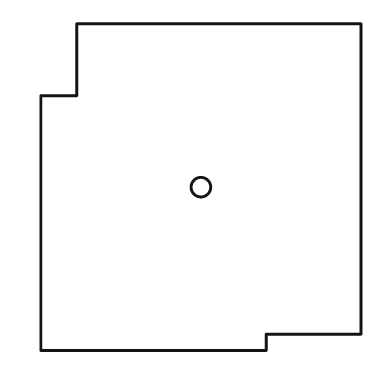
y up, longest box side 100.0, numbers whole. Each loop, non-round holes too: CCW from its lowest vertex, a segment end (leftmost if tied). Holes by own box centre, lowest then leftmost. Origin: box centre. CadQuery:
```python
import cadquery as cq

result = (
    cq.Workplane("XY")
    .moveTo(-49.0, -50.0)
    .lineTo(20.0, -50.0)
    .lineTo(20.0, -45.0)
    .lineTo(49.0, -45.0)
    .lineTo(49.0, 50.0)
    .lineTo(-38.0, 50.0)
    .lineTo(-38.0, 28.0)
    .lineTo(-49.0, 28.0)
    .close()
    .moveTo(0.0, 0.0)
    .circle(3.0)
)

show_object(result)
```